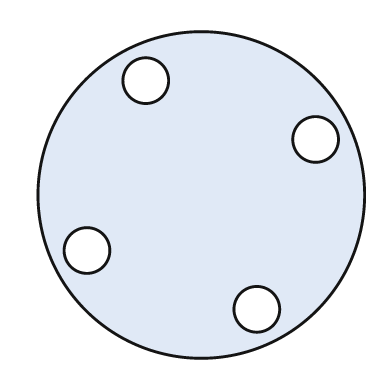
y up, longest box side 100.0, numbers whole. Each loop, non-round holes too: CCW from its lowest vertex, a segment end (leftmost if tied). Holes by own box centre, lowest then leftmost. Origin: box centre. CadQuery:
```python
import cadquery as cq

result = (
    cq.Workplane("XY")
    .moveTo(0.0, 0.0)
    .circle(50.0)
    .moveTo(17.0, -35.0)
    .circle(7.0)
    .moveTo(-35.0, -17.0)
    .circle(7.0)
    .moveTo(35.0, 17.0)
    .circle(7.0)
    .moveTo(-17.0, 35.0)
    .circle(7.0)
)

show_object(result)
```